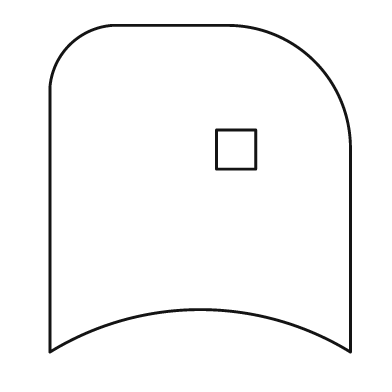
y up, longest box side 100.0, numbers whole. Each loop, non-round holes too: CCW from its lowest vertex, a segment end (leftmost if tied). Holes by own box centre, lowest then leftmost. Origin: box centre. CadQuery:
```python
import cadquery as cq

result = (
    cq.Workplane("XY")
    .moveTo(-46.0, -50.0)
    .threePointArc((0.0, -37.0), (46.0, -50.0))
    .lineTo(46.0, 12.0)
    .threePointArc((35.0, 39.0), (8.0, 50.0))
    .lineTo(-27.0, 50.0)
    .threePointArc((-40.0, 44.0), (-46.0, 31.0))
    .close()
    .moveTo(5.0, 6.0)
    .lineTo(17.0, 6.0)
    .lineTo(17.0, 18.0)
    .lineTo(5.0, 18.0)
    .close()
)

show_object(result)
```